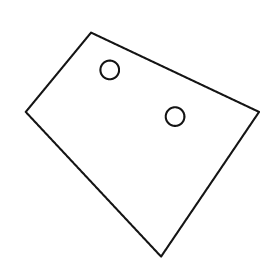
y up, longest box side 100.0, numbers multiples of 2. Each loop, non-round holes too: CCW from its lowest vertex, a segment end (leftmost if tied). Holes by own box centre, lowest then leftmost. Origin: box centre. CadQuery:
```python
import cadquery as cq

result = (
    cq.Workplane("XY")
    .moveTo(8.0, -48.0)
    .lineTo(50.0, 14.0)
    .lineTo(-22.0, 48.0)
    .lineTo(-50.0, 14.0)
    .close()
    .moveTo(14.0, 12.0)
    .circle(4.0)
    .moveTo(-14.0, 32.0)
    .circle(4.0)
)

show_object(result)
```